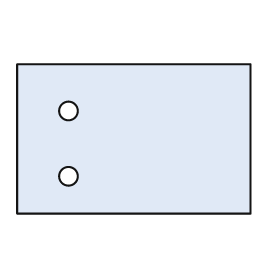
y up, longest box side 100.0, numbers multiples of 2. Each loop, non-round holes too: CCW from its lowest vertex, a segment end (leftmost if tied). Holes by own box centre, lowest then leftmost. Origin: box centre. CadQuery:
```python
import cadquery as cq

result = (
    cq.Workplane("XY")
    .moveTo(-50.0, -32.0)
    .lineTo(50.0, -32.0)
    .lineTo(50.0, 32.0)
    .lineTo(-50.0, 32.0)
    .close()
    .moveTo(-28.0, -16.0)
    .circle(4.0)
    .moveTo(-28.0, 12.0)
    .circle(4.0)
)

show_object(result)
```